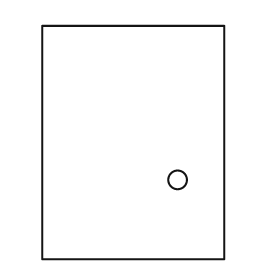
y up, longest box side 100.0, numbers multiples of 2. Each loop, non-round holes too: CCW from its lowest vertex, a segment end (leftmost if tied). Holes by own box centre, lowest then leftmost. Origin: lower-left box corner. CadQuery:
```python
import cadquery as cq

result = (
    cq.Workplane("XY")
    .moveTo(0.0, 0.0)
    .lineTo(78.0, 0.0)
    .lineTo(78.0, 100.0)
    .lineTo(0.0, 100.0)
    .close()
    .moveTo(58.0, 34.0)
    .circle(4.0)
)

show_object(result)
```